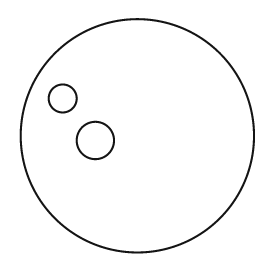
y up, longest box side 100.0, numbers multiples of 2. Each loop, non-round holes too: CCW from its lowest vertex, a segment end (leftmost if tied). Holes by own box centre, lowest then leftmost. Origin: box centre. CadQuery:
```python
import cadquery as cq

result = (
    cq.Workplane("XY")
    .moveTo(0.0, 0.0)
    .circle(50.0)
    .moveTo(-18.0, -2.0)
    .circle(8.0)
    .moveTo(-32.0, 16.0)
    .circle(6.0)
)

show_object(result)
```